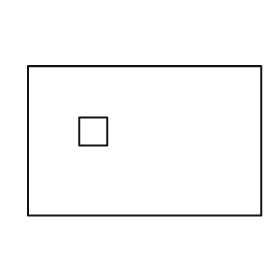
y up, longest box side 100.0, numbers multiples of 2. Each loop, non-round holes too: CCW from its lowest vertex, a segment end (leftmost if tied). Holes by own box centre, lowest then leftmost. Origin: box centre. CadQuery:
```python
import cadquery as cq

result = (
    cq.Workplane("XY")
    .moveTo(-50.0, -32.0)
    .lineTo(50.0, -32.0)
    .lineTo(50.0, 32.0)
    .lineTo(-50.0, 32.0)
    .close()
    .moveTo(-28.0, -2.0)
    .lineTo(-16.0, -2.0)
    .lineTo(-16.0, 10.0)
    .lineTo(-28.0, 10.0)
    .close()
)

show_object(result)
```